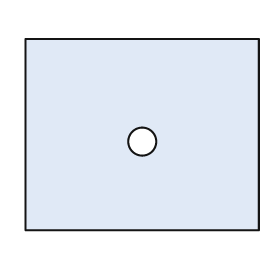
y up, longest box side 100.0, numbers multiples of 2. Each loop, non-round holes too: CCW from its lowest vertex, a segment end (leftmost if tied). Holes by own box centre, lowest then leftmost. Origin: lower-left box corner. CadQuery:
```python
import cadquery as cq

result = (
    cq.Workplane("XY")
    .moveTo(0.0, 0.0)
    .lineTo(100.0, 0.0)
    .lineTo(100.0, 82.0)
    .lineTo(0.0, 82.0)
    .close()
    .moveTo(50.0, 38.0)
    .circle(6.0)
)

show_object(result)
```